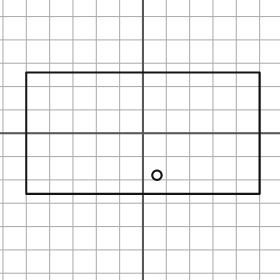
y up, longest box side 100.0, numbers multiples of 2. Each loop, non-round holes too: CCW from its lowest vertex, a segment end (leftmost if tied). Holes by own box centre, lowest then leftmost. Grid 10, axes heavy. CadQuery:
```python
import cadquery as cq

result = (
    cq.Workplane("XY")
    .moveTo(-50.0, -26.0)
    .lineTo(50.0, -26.0)
    .lineTo(50.0, 26.0)
    .lineTo(-50.0, 26.0)
    .close()
    .moveTo(6.0, -18.0)
    .circle(2.0)
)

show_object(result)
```